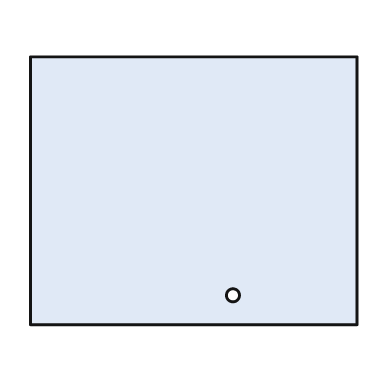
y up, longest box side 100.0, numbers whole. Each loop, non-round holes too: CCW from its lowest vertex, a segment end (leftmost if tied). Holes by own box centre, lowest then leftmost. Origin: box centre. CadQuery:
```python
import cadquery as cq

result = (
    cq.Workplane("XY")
    .moveTo(-50.0, -41.0)
    .lineTo(50.0, -41.0)
    .lineTo(50.0, 41.0)
    .lineTo(-50.0, 41.0)
    .close()
    .moveTo(12.0, -32.0)
    .circle(2.0)
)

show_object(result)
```